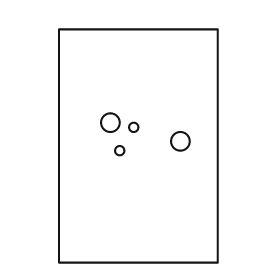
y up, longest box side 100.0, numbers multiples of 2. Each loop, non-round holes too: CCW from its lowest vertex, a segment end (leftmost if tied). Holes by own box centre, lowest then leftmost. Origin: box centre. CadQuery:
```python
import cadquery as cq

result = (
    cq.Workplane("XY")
    .moveTo(-34.0, -50.0)
    .lineTo(34.0, -50.0)
    .lineTo(34.0, 50.0)
    .lineTo(-34.0, 50.0)
    .close()
    .moveTo(-8.0, -2.0)
    .circle(2.0)
    .moveTo(18.0, 2.0)
    .circle(4.0)
    .moveTo(-2.0, 8.0)
    .circle(2.0)
    .moveTo(-12.0, 10.0)
    .circle(4.0)
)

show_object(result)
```